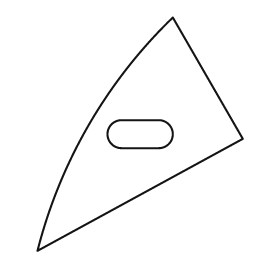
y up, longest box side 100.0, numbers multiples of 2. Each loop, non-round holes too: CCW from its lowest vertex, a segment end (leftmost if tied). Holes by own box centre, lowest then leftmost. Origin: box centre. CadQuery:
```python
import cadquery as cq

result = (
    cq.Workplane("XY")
    .moveTo(-44.0, -50.0)
    .lineTo(44.0, -2.0)
    .lineTo(14.0, 50.0)
    .threePointArc((-22.0, 4.0), (-44.0, -50.0))
    .close()
    .moveTo(-8.0, -6.0)
    .lineTo(8.0, -6.0)
    .threePointArc((14.0, 0.0), (8.0, 6.0))
    .lineTo(-8.0, 6.0)
    .threePointArc((-14.0, 0.0), (-8.0, -6.0))
    .close()
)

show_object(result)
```